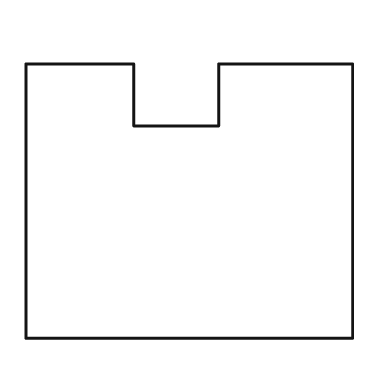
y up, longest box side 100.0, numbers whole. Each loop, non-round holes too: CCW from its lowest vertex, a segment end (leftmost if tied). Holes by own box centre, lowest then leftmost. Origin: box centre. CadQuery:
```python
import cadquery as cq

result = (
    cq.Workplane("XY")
    .moveTo(-50.0, -42.0)
    .lineTo(50.0, -42.0)
    .lineTo(50.0, 42.0)
    .lineTo(9.0, 42.0)
    .lineTo(9.0, 23.0)
    .lineTo(-17.0, 23.0)
    .lineTo(-17.0, 42.0)
    .lineTo(-50.0, 42.0)
    .close()
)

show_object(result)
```